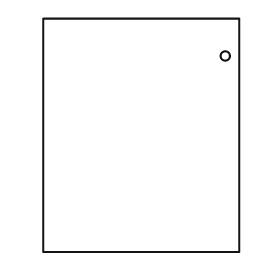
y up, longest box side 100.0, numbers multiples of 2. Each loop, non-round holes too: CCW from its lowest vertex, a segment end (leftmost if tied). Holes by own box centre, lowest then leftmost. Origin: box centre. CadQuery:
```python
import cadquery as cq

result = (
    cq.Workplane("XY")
    .moveTo(-42.0, -50.0)
    .lineTo(42.0, -50.0)
    .lineTo(42.0, 50.0)
    .lineTo(-42.0, 50.0)
    .close()
    .moveTo(36.0, 34.0)
    .circle(2.0)
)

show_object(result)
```